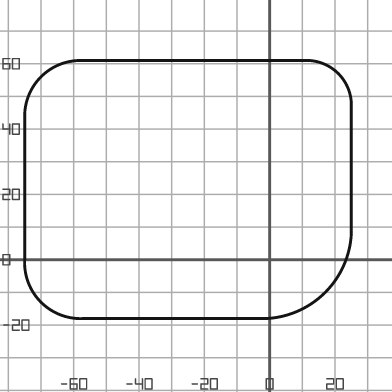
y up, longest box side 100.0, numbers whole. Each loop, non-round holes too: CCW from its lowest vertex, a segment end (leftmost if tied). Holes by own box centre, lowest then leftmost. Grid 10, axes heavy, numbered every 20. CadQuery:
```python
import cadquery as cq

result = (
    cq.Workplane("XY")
    .moveTo(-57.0, -18.0)
    .lineTo(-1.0, -18.0)
    .threePointArc((17.0, -10.0), (25.0, 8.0))
    .lineTo(25.0, 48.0)
    .threePointArc((21.0, 57.0), (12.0, 61.0))
    .lineTo(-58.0, 61.0)
    .threePointArc((-70.0, 56.0), (-75.0, 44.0))
    .lineTo(-75.0, 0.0)
    .threePointArc((-70.0, -13.0), (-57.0, -18.0))
    .close()
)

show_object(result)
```